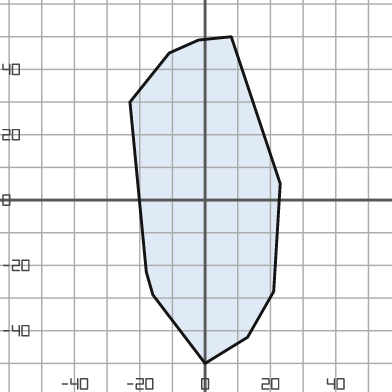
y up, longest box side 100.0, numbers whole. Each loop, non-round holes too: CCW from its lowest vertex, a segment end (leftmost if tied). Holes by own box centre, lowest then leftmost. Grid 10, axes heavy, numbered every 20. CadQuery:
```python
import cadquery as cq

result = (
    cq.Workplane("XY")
    .moveTo(0.0, -50.0)
    .lineTo(13.0, -42.0)
    .lineTo(21.0, -28.0)
    .lineTo(23.0, 5.0)
    .lineTo(8.0, 50.0)
    .lineTo(-2.0, 49.0)
    .lineTo(-11.0, 45.0)
    .lineTo(-23.0, 30.0)
    .lineTo(-18.0, -22.0)
    .lineTo(-16.0, -29.0)
    .close()
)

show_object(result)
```